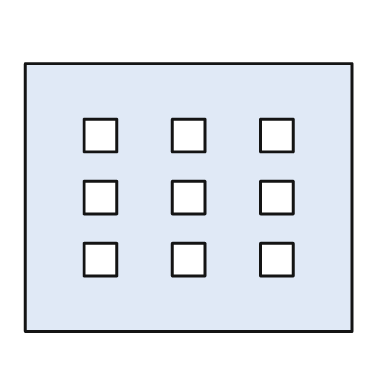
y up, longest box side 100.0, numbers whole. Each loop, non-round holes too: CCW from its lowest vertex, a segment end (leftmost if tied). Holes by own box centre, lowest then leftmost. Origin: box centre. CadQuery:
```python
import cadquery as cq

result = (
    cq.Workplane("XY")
    .moveTo(-50.0, -41.0)
    .lineTo(50.0, -41.0)
    .lineTo(50.0, 41.0)
    .lineTo(-50.0, 41.0)
    .close()
    .moveTo(-32.0, -24.0)
    .lineTo(-22.0, -24.0)
    .lineTo(-22.0, -14.0)
    .lineTo(-32.0, -14.0)
    .close()
    .moveTo(-5.0, -24.0)
    .lineTo(5.0, -24.0)
    .lineTo(5.0, -14.0)
    .lineTo(-5.0, -14.0)
    .close()
    .moveTo(22.0, -24.0)
    .lineTo(32.0, -24.0)
    .lineTo(32.0, -14.0)
    .lineTo(22.0, -14.0)
    .close()
    .moveTo(-32.0, -5.0)
    .lineTo(-22.0, -5.0)
    .lineTo(-22.0, 5.0)
    .lineTo(-32.0, 5.0)
    .close()
    .moveTo(-5.0, -5.0)
    .lineTo(5.0, -5.0)
    .lineTo(5.0, 5.0)
    .lineTo(-5.0, 5.0)
    .close()
    .moveTo(22.0, -5.0)
    .lineTo(32.0, -5.0)
    .lineTo(32.0, 5.0)
    .lineTo(22.0, 5.0)
    .close()
    .moveTo(-32.0, 14.0)
    .lineTo(-22.0, 14.0)
    .lineTo(-22.0, 24.0)
    .lineTo(-32.0, 24.0)
    .close()
    .moveTo(-5.0, 14.0)
    .lineTo(5.0, 14.0)
    .lineTo(5.0, 24.0)
    .lineTo(-5.0, 24.0)
    .close()
    .moveTo(22.0, 14.0)
    .lineTo(32.0, 14.0)
    .lineTo(32.0, 24.0)
    .lineTo(22.0, 24.0)
    .close()
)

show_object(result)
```